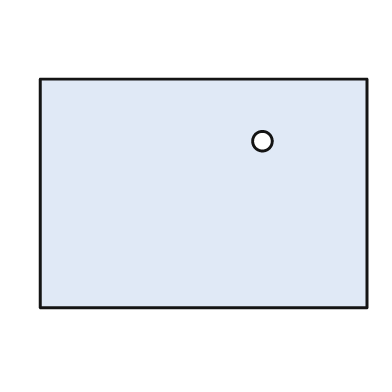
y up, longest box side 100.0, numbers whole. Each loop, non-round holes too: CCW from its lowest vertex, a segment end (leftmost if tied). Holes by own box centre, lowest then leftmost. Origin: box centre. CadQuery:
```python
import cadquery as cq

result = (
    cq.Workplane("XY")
    .moveTo(-50.0, -35.0)
    .lineTo(50.0, -35.0)
    .lineTo(50.0, 35.0)
    .lineTo(-50.0, 35.0)
    .close()
    .moveTo(18.0, 16.0)
    .circle(3.0)
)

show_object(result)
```